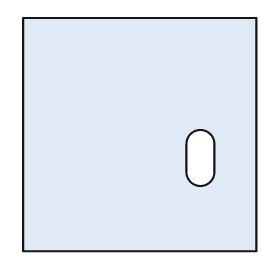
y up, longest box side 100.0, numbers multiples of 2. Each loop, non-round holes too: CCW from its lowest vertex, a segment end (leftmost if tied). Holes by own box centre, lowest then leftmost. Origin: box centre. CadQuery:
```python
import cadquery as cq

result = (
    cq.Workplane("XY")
    .moveTo(-50.0, -50.0)
    .lineTo(50.0, -50.0)
    .lineTo(50.0, 50.0)
    .lineTo(-50.0, 50.0)
    .close()
    .moveTo(20.0, -16.0)
    .threePointArc((26.0, -22.0), (32.0, -16.0))
    .lineTo(32.0, -4.0)
    .threePointArc((26.0, 2.0), (20.0, -4.0))
    .close()
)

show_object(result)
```